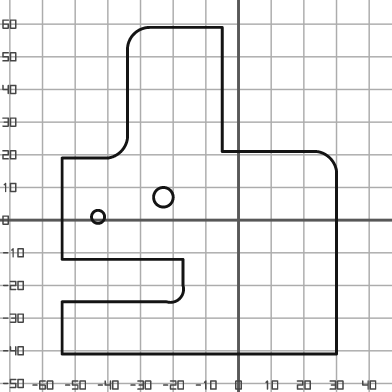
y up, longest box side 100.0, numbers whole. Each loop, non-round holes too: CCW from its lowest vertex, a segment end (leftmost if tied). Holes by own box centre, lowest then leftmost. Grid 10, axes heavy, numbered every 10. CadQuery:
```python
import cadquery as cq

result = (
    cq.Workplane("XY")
    .moveTo(-54.0, -41.0)
    .lineTo(30.0, -41.0)
    .lineTo(30.0, 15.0)
    .threePointArc((28.0, 19.0), (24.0, 21.0))
    .lineTo(-5.0, 21.0)
    .lineTo(-5.0, 59.0)
    .lineTo(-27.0, 59.0)
    .threePointArc((-32.0, 57.0), (-34.0, 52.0))
    .lineTo(-34.0, 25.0)
    .threePointArc((-36.0, 21.0), (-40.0, 19.0))
    .lineTo(-54.0, 19.0)
    .lineTo(-54.0, -12.0)
    .lineTo(-17.0, -12.0)
    .lineTo(-17.0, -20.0)
    .threePointArc((-18.0, -24.0), (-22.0, -25.0))
    .lineTo(-54.0, -25.0)
    .close()
    .moveTo(-43.0, 1.0)
    .circle(2.0)
    .moveTo(-23.0, 7.0)
    .circle(3.0)
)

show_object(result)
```